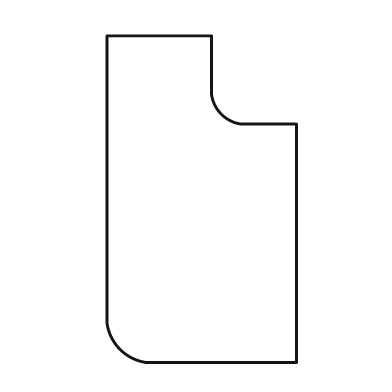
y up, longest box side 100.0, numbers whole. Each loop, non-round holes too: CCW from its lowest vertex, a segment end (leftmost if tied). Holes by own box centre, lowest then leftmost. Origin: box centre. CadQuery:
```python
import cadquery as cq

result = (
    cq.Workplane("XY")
    .moveTo(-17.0, -50.0)
    .lineTo(29.0, -50.0)
    .lineTo(29.0, 23.0)
    .lineTo(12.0, 23.0)
    .threePointArc((6.0, 26.0), (3.0, 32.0))
    .lineTo(3.0, 50.0)
    .lineTo(-29.0, 50.0)
    .lineTo(-29.0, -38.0)
    .threePointArc((-25.0, -46.0), (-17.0, -50.0))
    .close()
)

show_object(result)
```